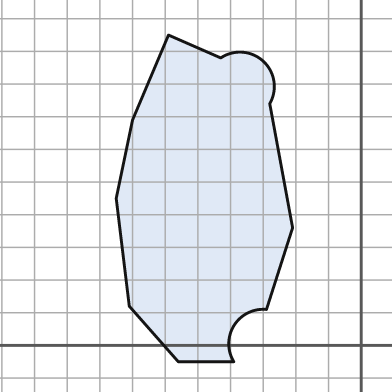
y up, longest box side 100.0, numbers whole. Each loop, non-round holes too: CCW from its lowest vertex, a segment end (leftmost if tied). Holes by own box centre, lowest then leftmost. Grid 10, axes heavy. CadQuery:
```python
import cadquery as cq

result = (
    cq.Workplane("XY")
    .moveTo(-56.0, -5.0)
    .lineTo(-39.0, -5.0)
    .threePointArc((-39.0, 6.0), (-29.0, 11.0))
    .lineTo(-21.0, 36.0)
    .lineTo(-28.0, 74.0)
    .threePointArc((-30.0, 87.0), (-43.0, 88.0))
    .lineTo(-59.0, 95.0)
    .lineTo(-70.0, 69.0)
    .lineTo(-75.0, 45.0)
    .lineTo(-71.0, 12.0)
    .close()
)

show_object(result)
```